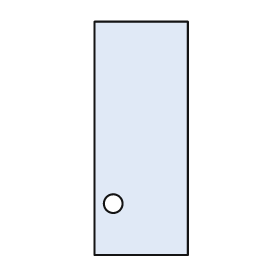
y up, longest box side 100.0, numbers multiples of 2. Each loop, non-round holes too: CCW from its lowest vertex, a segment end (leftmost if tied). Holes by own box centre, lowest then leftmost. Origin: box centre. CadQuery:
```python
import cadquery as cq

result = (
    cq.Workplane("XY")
    .moveTo(-20.0, -50.0)
    .lineTo(20.0, -50.0)
    .lineTo(20.0, 50.0)
    .lineTo(-20.0, 50.0)
    .close()
    .moveTo(-12.0, -28.0)
    .circle(4.0)
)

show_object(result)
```